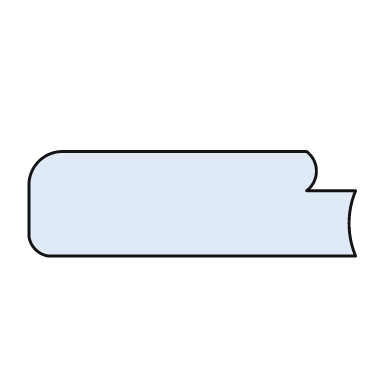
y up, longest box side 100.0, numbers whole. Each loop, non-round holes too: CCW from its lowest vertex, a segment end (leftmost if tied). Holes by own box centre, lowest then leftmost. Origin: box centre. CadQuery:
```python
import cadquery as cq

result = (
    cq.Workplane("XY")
    .moveTo(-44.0, -16.0)
    .lineTo(50.0, -16.0)
    .threePointArc((48.0, -6.0), (50.0, 4.0))
    .lineTo(35.0, 4.0)
    .threePointArc((38.0, 10.0), (35.0, 16.0))
    .lineTo(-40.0, 16.0)
    .threePointArc((-47.0, 13.0), (-50.0, 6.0))
    .lineTo(-50.0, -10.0)
    .threePointArc((-48.0, -14.0), (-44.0, -16.0))
    .close()
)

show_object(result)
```